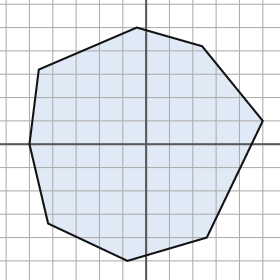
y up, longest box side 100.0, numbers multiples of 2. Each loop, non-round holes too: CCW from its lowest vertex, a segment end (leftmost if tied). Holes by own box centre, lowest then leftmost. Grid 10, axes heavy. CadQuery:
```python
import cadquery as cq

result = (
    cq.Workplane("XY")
    .moveTo(-8.0, -50.0)
    .lineTo(26.0, -40.0)
    .lineTo(50.0, 10.0)
    .lineTo(24.0, 42.0)
    .lineTo(-4.0, 50.0)
    .lineTo(-46.0, 32.0)
    .lineTo(-50.0, 0.0)
    .lineTo(-42.0, -34.0)
    .close()
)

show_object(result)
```